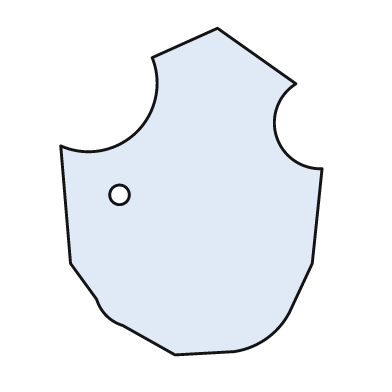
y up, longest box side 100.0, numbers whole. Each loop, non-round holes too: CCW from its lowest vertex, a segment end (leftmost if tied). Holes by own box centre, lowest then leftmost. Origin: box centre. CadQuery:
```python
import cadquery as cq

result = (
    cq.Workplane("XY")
    .moveTo(-5.0, -50.0)
    .lineTo(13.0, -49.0)
    .threePointArc((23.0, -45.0), (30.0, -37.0))
    .lineTo(37.0, -22.0)
    .lineTo(40.0, 7.0)
    .threePointArc((26.0, 17.0), (32.0, 33.0))
    .lineTo(8.0, 50.0)
    .lineTo(-12.0, 41.0)
    .threePointArc((-17.0, 18.0), (-40.0, 14.0))
    .lineTo(-37.0, -22.0)
    .lineTo(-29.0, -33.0)
    .threePointArc((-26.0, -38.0), (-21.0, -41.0))
    .close()
    .moveTo(-22.0, -1.0)
    .circle(3.0)
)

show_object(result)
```